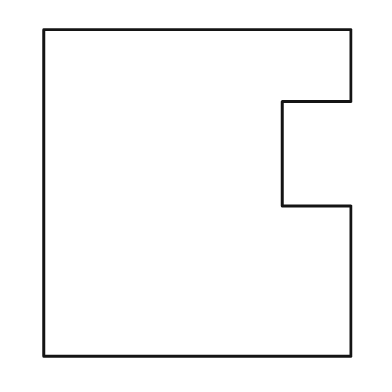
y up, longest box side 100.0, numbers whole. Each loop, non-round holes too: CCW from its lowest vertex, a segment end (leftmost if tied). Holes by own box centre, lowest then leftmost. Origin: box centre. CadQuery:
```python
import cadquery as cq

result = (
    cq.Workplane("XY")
    .moveTo(-47.0, -50.0)
    .lineTo(47.0, -50.0)
    .lineTo(47.0, -4.0)
    .lineTo(26.0, -4.0)
    .lineTo(26.0, 28.0)
    .lineTo(47.0, 28.0)
    .lineTo(47.0, 50.0)
    .lineTo(-47.0, 50.0)
    .close()
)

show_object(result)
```